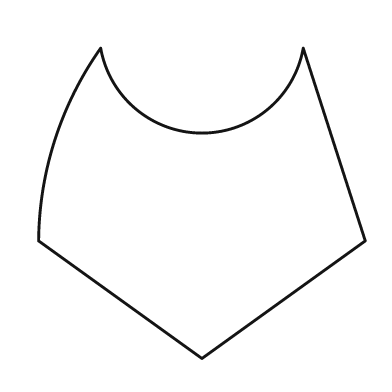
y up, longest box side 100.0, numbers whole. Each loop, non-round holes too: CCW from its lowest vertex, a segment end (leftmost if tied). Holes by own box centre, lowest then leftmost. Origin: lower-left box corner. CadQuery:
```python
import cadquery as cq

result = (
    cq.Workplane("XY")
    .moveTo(50.0, 0.0)
    .lineTo(100.0, 36.0)
    .lineTo(81.0, 95.0)
    .threePointArc((50.0, 69.0), (19.0, 95.0))
    .threePointArc((5.0, 67.0), (0.0, 36.0))
    .close()
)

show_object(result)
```